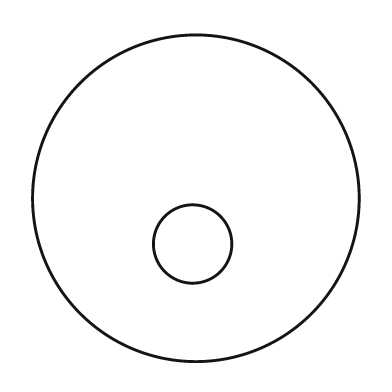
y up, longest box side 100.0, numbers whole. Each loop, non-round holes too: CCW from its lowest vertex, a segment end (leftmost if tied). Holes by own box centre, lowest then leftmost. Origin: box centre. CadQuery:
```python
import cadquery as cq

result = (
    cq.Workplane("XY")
    .moveTo(0.0, 0.0)
    .circle(50.0)
    .moveTo(-1.0, -14.0)
    .circle(12.0)
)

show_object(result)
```